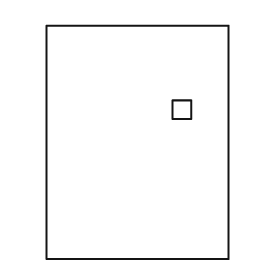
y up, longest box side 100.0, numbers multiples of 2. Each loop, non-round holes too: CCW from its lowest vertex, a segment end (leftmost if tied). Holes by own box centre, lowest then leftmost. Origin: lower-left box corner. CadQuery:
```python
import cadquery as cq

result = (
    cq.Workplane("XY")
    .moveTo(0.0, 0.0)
    .lineTo(78.0, 0.0)
    .lineTo(78.0, 100.0)
    .lineTo(0.0, 100.0)
    .close()
    .moveTo(54.0, 60.0)
    .lineTo(62.0, 60.0)
    .lineTo(62.0, 68.0)
    .lineTo(54.0, 68.0)
    .close()
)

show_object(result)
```